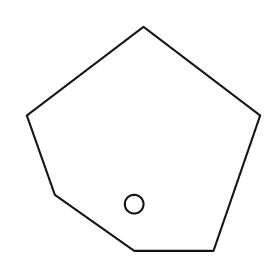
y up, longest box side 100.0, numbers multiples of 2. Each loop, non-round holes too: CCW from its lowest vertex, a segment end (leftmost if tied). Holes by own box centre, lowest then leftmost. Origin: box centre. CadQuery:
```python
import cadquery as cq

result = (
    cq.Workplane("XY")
    .moveTo(-4.0, -48.0)
    .lineTo(30.0, -48.0)
    .lineTo(50.0, 10.0)
    .lineTo(0.0, 48.0)
    .lineTo(-50.0, 10.0)
    .lineTo(-38.0, -24.0)
    .close()
    .moveTo(-4.0, -28.0)
    .circle(4.0)
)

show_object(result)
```